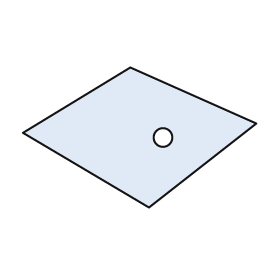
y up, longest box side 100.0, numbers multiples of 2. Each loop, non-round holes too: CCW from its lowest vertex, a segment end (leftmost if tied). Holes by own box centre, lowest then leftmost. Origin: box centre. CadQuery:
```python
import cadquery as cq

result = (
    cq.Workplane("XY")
    .moveTo(4.0, -30.0)
    .lineTo(50.0, 6.0)
    .lineTo(-4.0, 30.0)
    .lineTo(-50.0, 2.0)
    .close()
    .moveTo(10.0, 0.0)
    .circle(4.0)
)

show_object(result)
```